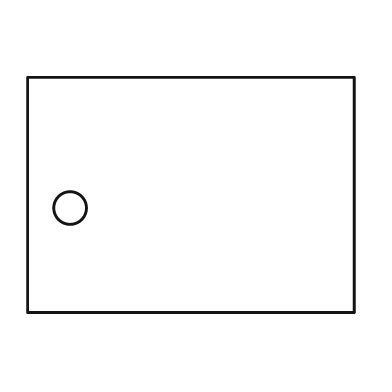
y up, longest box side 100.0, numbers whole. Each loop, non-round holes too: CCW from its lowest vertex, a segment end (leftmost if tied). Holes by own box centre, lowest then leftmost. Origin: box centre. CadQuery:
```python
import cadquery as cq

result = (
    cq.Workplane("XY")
    .moveTo(-50.0, -36.0)
    .lineTo(50.0, -36.0)
    .lineTo(50.0, 36.0)
    .lineTo(-50.0, 36.0)
    .close()
    .moveTo(-37.0, -4.0)
    .circle(5.0)
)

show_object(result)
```